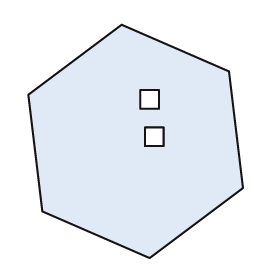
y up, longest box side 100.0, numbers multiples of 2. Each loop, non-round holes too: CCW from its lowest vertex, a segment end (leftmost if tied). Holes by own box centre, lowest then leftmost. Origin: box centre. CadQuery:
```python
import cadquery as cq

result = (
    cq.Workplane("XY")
    .moveTo(6.0, -50.0)
    .lineTo(46.0, -20.0)
    .lineTo(40.0, 30.0)
    .lineTo(-6.0, 50.0)
    .lineTo(-46.0, 20.0)
    .lineTo(-40.0, -30.0)
    .close()
    .moveTo(4.0, -2.0)
    .lineTo(12.0, -2.0)
    .lineTo(12.0, 6.0)
    .lineTo(4.0, 6.0)
    .close()
    .moveTo(2.0, 14.0)
    .lineTo(10.0, 14.0)
    .lineTo(10.0, 22.0)
    .lineTo(2.0, 22.0)
    .close()
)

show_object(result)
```